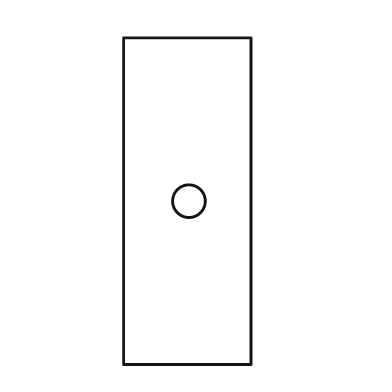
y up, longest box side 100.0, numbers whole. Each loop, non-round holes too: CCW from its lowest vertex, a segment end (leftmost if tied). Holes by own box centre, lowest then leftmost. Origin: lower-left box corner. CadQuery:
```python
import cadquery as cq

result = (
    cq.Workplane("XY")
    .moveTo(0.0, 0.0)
    .lineTo(39.0, 0.0)
    .lineTo(39.0, 100.0)
    .lineTo(0.0, 100.0)
    .close()
    .moveTo(20.0, 50.0)
    .circle(5.0)
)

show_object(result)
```